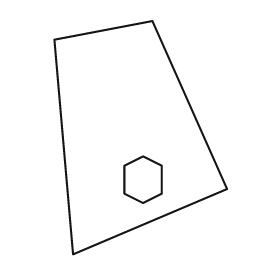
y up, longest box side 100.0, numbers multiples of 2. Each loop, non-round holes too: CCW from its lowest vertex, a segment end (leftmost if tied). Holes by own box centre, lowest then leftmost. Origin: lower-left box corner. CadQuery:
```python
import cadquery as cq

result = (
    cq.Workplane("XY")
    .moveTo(8.0, 0.0)
    .lineTo(74.0, 28.0)
    .lineTo(42.0, 100.0)
    .lineTo(0.0, 92.0)
    .close()
    .moveTo(38.0, 22.0)
    .lineTo(46.0, 26.0)
    .lineTo(46.0, 38.0)
    .lineTo(38.0, 42.0)
    .lineTo(30.0, 38.0)
    .lineTo(30.0, 26.0)
    .close()
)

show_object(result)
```